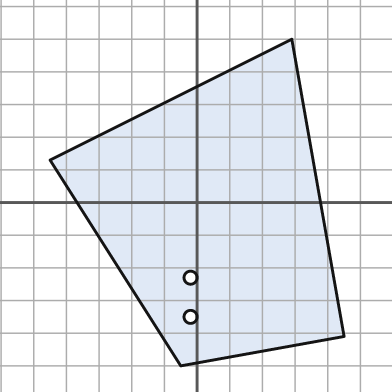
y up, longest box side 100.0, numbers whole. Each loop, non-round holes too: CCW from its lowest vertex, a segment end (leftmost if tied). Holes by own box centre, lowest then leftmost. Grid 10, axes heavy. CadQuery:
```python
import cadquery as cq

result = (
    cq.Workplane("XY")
    .moveTo(-5.0, -50.0)
    .lineTo(45.0, -41.0)
    .lineTo(29.0, 50.0)
    .lineTo(-45.0, 13.0)
    .close()
    .moveTo(-2.0, -35.0)
    .circle(2.0)
    .moveTo(-2.0, -23.0)
    .circle(2.0)
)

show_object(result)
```